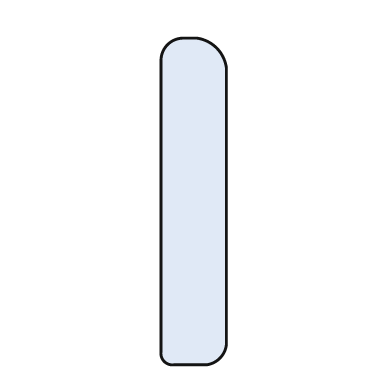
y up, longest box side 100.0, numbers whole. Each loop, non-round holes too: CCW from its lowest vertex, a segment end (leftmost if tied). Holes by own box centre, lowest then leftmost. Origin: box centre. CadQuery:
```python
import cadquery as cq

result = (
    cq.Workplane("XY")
    .moveTo(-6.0, -50.0)
    .lineTo(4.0, -50.0)
    .threePointArc((8.0, -48.0), (10.0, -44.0))
    .lineTo(10.0, 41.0)
    .threePointArc((7.0, 47.0), (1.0, 50.0))
    .lineTo(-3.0, 50.0)
    .threePointArc((-8.0, 48.0), (-10.0, 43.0))
    .lineTo(-10.0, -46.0)
    .threePointArc((-9.0, -49.0), (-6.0, -50.0))
    .close()
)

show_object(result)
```